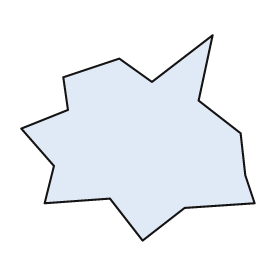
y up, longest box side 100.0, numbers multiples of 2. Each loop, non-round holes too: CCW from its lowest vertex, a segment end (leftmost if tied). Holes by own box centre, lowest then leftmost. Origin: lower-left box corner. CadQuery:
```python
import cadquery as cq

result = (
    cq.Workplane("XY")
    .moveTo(52.0, 0.0)
    .lineTo(70.0, 14.0)
    .lineTo(100.0, 16.0)
    .lineTo(96.0, 28.0)
    .lineTo(94.0, 46.0)
    .lineTo(76.0, 60.0)
    .lineTo(82.0, 88.0)
    .lineTo(56.0, 68.0)
    .lineTo(42.0, 78.0)
    .lineTo(18.0, 70.0)
    .lineTo(20.0, 56.0)
    .lineTo(0.0, 48.0)
    .lineTo(14.0, 32.0)
    .lineTo(10.0, 16.0)
    .lineTo(38.0, 18.0)
    .close()
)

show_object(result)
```